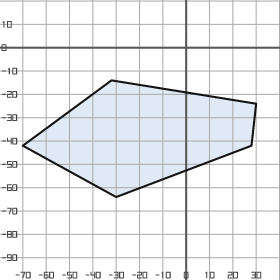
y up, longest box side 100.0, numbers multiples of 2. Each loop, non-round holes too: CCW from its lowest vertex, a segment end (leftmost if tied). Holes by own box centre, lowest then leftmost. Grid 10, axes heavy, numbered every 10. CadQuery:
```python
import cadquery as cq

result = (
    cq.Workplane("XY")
    .moveTo(-30.0, -64.0)
    .lineTo(28.0, -42.0)
    .lineTo(30.0, -24.0)
    .lineTo(-32.0, -14.0)
    .lineTo(-70.0, -42.0)
    .close()
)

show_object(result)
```